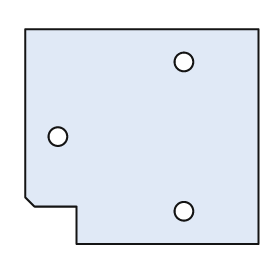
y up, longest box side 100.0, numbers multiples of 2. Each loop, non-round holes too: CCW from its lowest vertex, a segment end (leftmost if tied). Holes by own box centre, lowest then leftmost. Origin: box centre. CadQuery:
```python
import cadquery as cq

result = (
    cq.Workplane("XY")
    .moveTo(-28.0, -46.0)
    .lineTo(50.0, -46.0)
    .lineTo(50.0, 46.0)
    .lineTo(-50.0, 46.0)
    .lineTo(-50.0, -26.0)
    .lineTo(-46.0, -30.0)
    .lineTo(-28.0, -30.0)
    .close()
    .moveTo(18.0, -32.0)
    .circle(4.0)
    .moveTo(-36.0, 0.0)
    .circle(4.0)
    .moveTo(18.0, 32.0)
    .circle(4.0)
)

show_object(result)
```